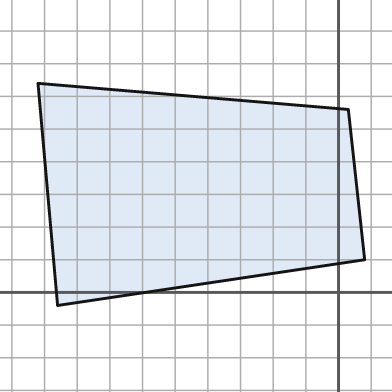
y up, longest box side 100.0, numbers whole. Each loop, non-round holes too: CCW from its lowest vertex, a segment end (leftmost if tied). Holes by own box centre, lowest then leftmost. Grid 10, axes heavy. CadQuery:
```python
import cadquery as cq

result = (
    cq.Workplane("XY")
    .moveTo(-86.0, -4.0)
    .lineTo(8.0, 10.0)
    .lineTo(3.0, 56.0)
    .lineTo(-92.0, 64.0)
    .close()
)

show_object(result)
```